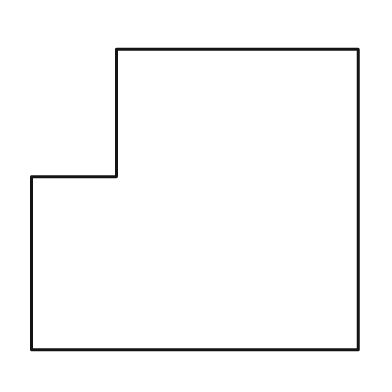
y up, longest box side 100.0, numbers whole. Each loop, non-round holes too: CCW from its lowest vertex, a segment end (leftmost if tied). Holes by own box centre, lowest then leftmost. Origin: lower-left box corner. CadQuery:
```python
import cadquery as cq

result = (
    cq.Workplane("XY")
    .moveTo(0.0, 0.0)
    .lineTo(100.0, 0.0)
    .lineTo(100.0, 92.0)
    .lineTo(26.0, 92.0)
    .lineTo(26.0, 53.0)
    .lineTo(0.0, 53.0)
    .close()
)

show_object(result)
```